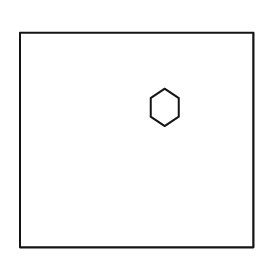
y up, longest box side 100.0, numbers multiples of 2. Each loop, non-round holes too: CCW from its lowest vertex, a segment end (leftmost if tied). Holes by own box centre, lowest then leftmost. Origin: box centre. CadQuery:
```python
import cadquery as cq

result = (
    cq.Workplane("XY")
    .moveTo(-50.0, -46.0)
    .lineTo(50.0, -46.0)
    .lineTo(50.0, 46.0)
    .lineTo(-50.0, 46.0)
    .close()
    .moveTo(12.0, 6.0)
    .lineTo(18.0, 10.0)
    .lineTo(18.0, 18.0)
    .lineTo(12.0, 22.0)
    .lineTo(6.0, 18.0)
    .lineTo(6.0, 10.0)
    .close()
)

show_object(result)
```